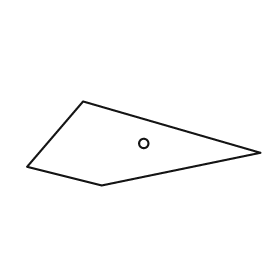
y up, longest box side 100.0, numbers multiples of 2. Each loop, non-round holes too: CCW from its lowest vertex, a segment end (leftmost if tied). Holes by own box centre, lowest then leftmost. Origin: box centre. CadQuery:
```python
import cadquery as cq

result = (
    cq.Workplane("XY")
    .moveTo(-18.0, -18.0)
    .lineTo(50.0, -4.0)
    .lineTo(-26.0, 18.0)
    .lineTo(-50.0, -10.0)
    .close()
    .moveTo(0.0, 0.0)
    .circle(2.0)
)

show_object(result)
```